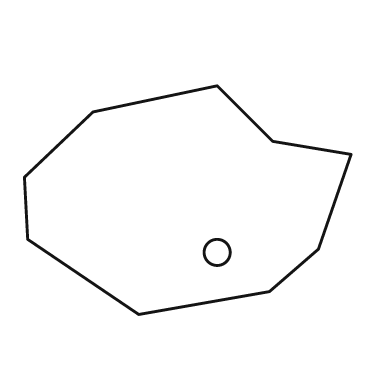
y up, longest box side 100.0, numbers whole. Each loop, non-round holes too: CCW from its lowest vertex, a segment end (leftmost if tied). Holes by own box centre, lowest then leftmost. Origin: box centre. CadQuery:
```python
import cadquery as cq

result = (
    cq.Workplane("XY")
    .moveTo(-15.0, -35.0)
    .lineTo(25.0, -28.0)
    .lineTo(40.0, -15.0)
    .lineTo(50.0, 14.0)
    .lineTo(26.0, 18.0)
    .lineTo(9.0, 35.0)
    .lineTo(-29.0, 27.0)
    .lineTo(-50.0, 7.0)
    .lineTo(-49.0, -12.0)
    .close()
    .moveTo(9.0, -16.0)
    .circle(4.0)
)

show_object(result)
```